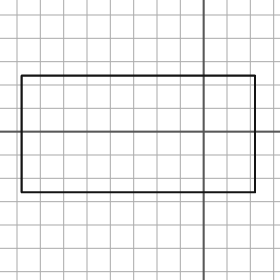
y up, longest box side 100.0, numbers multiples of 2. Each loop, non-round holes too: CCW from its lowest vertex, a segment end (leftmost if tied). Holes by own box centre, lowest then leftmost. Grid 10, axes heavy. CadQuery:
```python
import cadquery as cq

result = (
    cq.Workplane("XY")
    .moveTo(-78.0, -26.0)
    .lineTo(22.0, -26.0)
    .lineTo(22.0, 24.0)
    .lineTo(-78.0, 24.0)
    .close()
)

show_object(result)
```